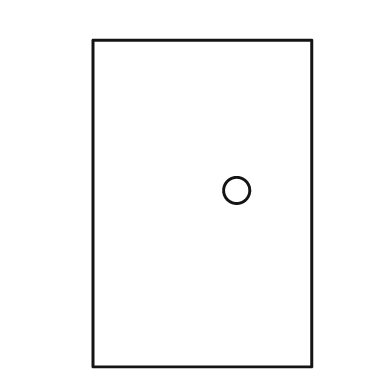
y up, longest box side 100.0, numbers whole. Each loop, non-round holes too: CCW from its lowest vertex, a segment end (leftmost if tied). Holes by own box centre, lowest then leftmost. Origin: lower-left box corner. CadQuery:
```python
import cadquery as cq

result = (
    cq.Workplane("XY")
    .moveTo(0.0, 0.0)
    .lineTo(67.0, 0.0)
    .lineTo(67.0, 100.0)
    .lineTo(0.0, 100.0)
    .close()
    .moveTo(44.0, 54.0)
    .circle(4.0)
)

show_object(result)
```